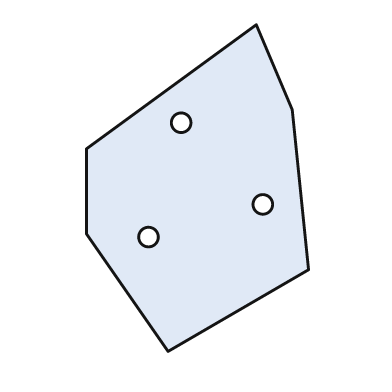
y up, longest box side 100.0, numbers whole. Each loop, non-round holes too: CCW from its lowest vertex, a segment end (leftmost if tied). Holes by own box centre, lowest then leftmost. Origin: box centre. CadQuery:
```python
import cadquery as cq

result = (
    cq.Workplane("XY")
    .moveTo(-9.0, -50.0)
    .lineTo(34.0, -25.0)
    .lineTo(29.0, 24.0)
    .lineTo(18.0, 50.0)
    .lineTo(-34.0, 12.0)
    .lineTo(-34.0, -14.0)
    .close()
    .moveTo(-15.0, -15.0)
    .circle(3.0)
    .moveTo(20.0, -5.0)
    .circle(3.0)
    .moveTo(-5.0, 20.0)
    .circle(3.0)
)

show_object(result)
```